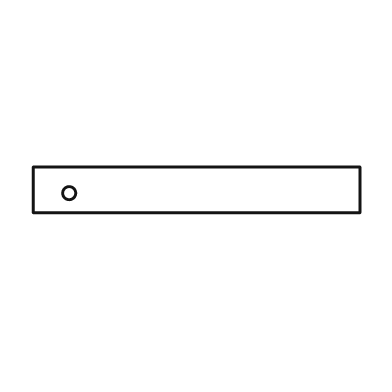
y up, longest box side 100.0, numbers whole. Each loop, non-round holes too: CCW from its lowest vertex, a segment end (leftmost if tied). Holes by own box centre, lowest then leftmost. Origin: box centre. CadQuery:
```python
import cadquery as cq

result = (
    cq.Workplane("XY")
    .moveTo(-50.0, -7.0)
    .lineTo(50.0, -7.0)
    .lineTo(50.0, 7.0)
    .lineTo(-50.0, 7.0)
    .close()
    .moveTo(-39.0, -1.0)
    .circle(2.0)
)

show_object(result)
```